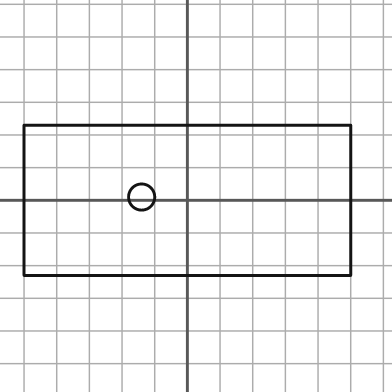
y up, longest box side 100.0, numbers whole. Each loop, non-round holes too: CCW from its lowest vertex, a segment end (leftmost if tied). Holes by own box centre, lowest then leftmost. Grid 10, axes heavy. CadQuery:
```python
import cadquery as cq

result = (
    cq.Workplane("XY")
    .moveTo(-50.0, -23.0)
    .lineTo(50.0, -23.0)
    .lineTo(50.0, 23.0)
    .lineTo(-50.0, 23.0)
    .close()
    .moveTo(-14.0, 1.0)
    .circle(4.0)
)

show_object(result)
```